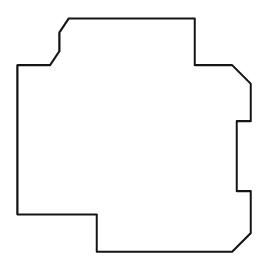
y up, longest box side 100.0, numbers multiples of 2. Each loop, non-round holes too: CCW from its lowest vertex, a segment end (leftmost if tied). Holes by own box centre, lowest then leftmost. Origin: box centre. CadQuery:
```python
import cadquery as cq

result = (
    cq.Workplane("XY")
    .moveTo(-16.0, -50.0)
    .lineTo(42.0, -50.0)
    .lineTo(50.0, -42.0)
    .lineTo(50.0, -24.0)
    .lineTo(44.0, -24.0)
    .lineTo(44.0, 6.0)
    .lineTo(50.0, 6.0)
    .lineTo(50.0, 22.0)
    .lineTo(42.0, 30.0)
    .lineTo(26.0, 30.0)
    .lineTo(26.0, 50.0)
    .lineTo(-28.0, 50.0)
    .lineTo(-32.0, 44.0)
    .lineTo(-32.0, 36.0)
    .lineTo(-36.0, 30.0)
    .lineTo(-50.0, 30.0)
    .lineTo(-50.0, -34.0)
    .lineTo(-16.0, -34.0)
    .close()
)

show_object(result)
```